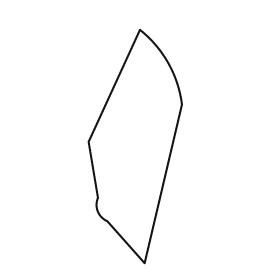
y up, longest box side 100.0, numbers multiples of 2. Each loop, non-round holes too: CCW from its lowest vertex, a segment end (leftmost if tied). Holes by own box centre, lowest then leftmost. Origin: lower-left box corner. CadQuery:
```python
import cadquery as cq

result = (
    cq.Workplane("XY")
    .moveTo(24.0, 0.0)
    .lineTo(40.0, 68.0)
    .threePointArc((34.0, 86.0), (22.0, 100.0))
    .lineTo(0.0, 52.0)
    .lineTo(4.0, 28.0)
    .threePointArc((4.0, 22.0), (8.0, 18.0))
    .close()
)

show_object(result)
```